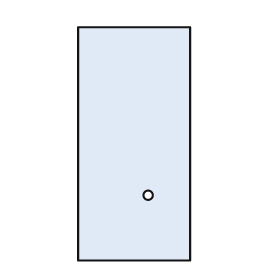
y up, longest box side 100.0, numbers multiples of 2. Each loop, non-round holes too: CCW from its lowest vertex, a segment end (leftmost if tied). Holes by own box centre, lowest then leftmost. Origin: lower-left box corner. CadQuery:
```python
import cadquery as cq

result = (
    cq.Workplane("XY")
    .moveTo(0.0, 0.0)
    .lineTo(48.0, 0.0)
    .lineTo(48.0, 100.0)
    .lineTo(0.0, 100.0)
    .close()
    .moveTo(30.0, 28.0)
    .circle(2.0)
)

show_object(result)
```